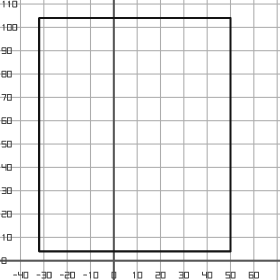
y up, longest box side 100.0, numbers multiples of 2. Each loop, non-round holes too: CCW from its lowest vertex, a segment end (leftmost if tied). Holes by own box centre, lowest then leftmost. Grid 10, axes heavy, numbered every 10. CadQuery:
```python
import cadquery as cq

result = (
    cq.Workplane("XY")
    .moveTo(-32.0, 4.0)
    .lineTo(50.0, 4.0)
    .lineTo(50.0, 104.0)
    .lineTo(-32.0, 104.0)
    .close()
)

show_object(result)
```